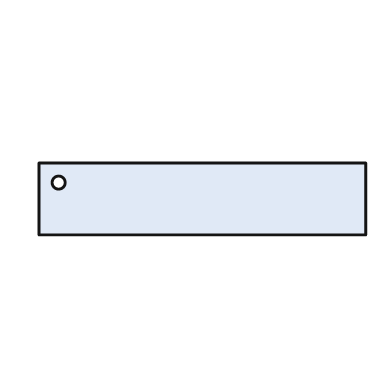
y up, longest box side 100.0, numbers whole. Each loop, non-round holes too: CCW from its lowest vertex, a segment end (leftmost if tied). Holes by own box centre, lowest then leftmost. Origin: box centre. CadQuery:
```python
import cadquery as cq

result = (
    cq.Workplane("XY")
    .moveTo(-50.0, -11.0)
    .lineTo(50.0, -11.0)
    .lineTo(50.0, 11.0)
    .lineTo(-50.0, 11.0)
    .close()
    .moveTo(-44.0, 5.0)
    .circle(2.0)
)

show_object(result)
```